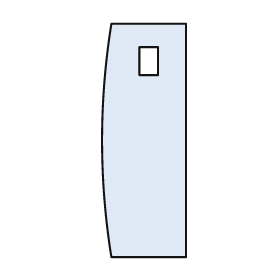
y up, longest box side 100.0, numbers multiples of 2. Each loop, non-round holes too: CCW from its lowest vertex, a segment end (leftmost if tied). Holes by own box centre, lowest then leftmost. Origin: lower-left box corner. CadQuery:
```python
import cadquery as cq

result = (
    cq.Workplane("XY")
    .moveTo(4.0, 0.0)
    .lineTo(36.0, 0.0)
    .lineTo(36.0, 100.0)
    .lineTo(4.0, 100.0)
    .threePointArc((0.0, 50.0), (4.0, 0.0))
    .close()
    .moveTo(16.0, 78.0)
    .lineTo(24.0, 78.0)
    .lineTo(24.0, 90.0)
    .lineTo(16.0, 90.0)
    .close()
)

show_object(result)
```